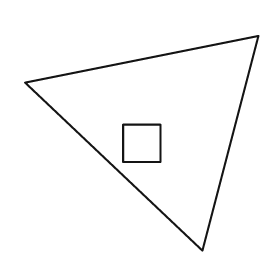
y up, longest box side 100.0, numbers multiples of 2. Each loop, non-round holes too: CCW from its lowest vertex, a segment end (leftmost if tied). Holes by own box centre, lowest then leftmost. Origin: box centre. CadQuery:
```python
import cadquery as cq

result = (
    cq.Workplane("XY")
    .moveTo(26.0, -46.0)
    .lineTo(50.0, 46.0)
    .lineTo(-50.0, 26.0)
    .close()
    .moveTo(-8.0, -8.0)
    .lineTo(8.0, -8.0)
    .lineTo(8.0, 8.0)
    .lineTo(-8.0, 8.0)
    .close()
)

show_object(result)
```